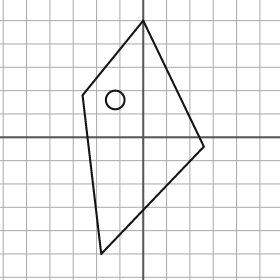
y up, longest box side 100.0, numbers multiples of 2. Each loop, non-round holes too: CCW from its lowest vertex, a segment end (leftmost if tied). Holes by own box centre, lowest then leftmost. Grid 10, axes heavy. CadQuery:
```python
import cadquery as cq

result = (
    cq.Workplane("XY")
    .moveTo(-18.0, -50.0)
    .lineTo(26.0, -4.0)
    .lineTo(0.0, 50.0)
    .lineTo(-26.0, 18.0)
    .close()
    .moveTo(-12.0, 16.0)
    .circle(4.0)
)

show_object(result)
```